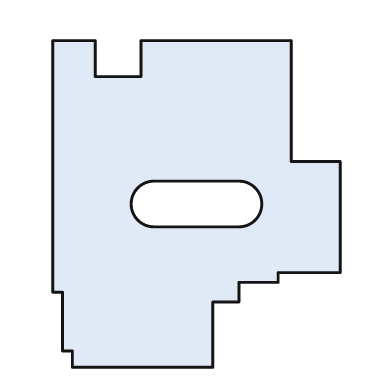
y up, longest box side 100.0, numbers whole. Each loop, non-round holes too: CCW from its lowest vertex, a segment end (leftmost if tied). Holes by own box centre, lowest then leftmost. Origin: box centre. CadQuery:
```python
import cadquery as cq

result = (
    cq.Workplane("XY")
    .moveTo(-38.0, -50.0)
    .lineTo(5.0, -50.0)
    .lineTo(5.0, -30.0)
    .lineTo(13.0, -30.0)
    .lineTo(13.0, -24.0)
    .lineTo(25.0, -24.0)
    .lineTo(25.0, -21.0)
    .lineTo(44.0, -21.0)
    .lineTo(44.0, 13.0)
    .lineTo(29.0, 13.0)
    .lineTo(29.0, 50.0)
    .lineTo(-17.0, 50.0)
    .lineTo(-17.0, 39.0)
    .lineTo(-31.0, 39.0)
    .lineTo(-31.0, 50.0)
    .lineTo(-44.0, 50.0)
    .lineTo(-44.0, -27.0)
    .lineTo(-41.0, -27.0)
    .lineTo(-41.0, -45.0)
    .lineTo(-38.0, -45.0)
    .close()
    .moveTo(-13.0, -7.0)
    .lineTo(13.0, -7.0)
    .threePointArc((20.0, 0.0), (13.0, 7.0))
    .lineTo(-13.0, 7.0)
    .threePointArc((-20.0, 0.0), (-13.0, -7.0))
    .close()
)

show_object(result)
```